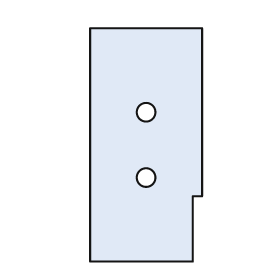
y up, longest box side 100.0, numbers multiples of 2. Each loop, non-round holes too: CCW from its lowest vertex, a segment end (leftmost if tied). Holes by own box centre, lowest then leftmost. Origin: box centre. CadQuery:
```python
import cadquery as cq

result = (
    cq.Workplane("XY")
    .moveTo(-24.0, -50.0)
    .lineTo(20.0, -50.0)
    .lineTo(20.0, -22.0)
    .lineTo(24.0, -22.0)
    .lineTo(24.0, 50.0)
    .lineTo(-24.0, 50.0)
    .close()
    .moveTo(0.0, -14.0)
    .circle(4.0)
    .moveTo(0.0, 14.0)
    .circle(4.0)
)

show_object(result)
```